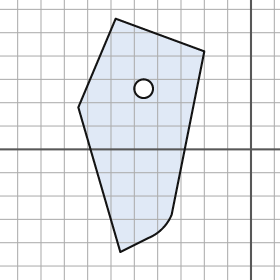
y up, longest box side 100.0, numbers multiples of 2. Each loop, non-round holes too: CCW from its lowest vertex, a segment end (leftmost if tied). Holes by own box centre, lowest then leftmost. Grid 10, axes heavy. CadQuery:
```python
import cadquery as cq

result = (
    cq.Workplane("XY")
    .moveTo(-56.0, -44.0)
    .lineTo(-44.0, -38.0)
    .threePointArc((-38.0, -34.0), (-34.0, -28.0))
    .lineTo(-20.0, 42.0)
    .lineTo(-58.0, 56.0)
    .lineTo(-74.0, 18.0)
    .close()
    .moveTo(-46.0, 26.0)
    .circle(4.0)
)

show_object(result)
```